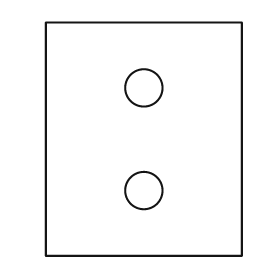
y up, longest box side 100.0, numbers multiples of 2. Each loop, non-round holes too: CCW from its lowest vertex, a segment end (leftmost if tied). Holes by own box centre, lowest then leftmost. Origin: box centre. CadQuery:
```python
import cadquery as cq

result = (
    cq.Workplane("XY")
    .moveTo(-42.0, -50.0)
    .lineTo(42.0, -50.0)
    .lineTo(42.0, 50.0)
    .lineTo(-42.0, 50.0)
    .close()
    .moveTo(0.0, -22.0)
    .circle(8.0)
    .moveTo(0.0, 22.0)
    .circle(8.0)
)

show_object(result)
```